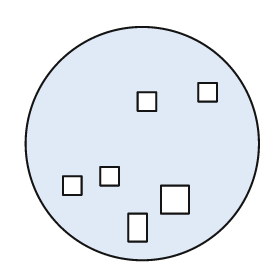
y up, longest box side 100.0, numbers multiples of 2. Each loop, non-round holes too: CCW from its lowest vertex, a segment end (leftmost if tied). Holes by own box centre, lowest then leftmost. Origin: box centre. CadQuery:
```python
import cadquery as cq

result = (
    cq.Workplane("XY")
    .moveTo(0.0, 0.0)
    .circle(50.0)
    .moveTo(-6.0, -42.0)
    .lineTo(2.0, -42.0)
    .lineTo(2.0, -30.0)
    .lineTo(-6.0, -30.0)
    .close()
    .moveTo(8.0, -30.0)
    .lineTo(20.0, -30.0)
    .lineTo(20.0, -18.0)
    .lineTo(8.0, -18.0)
    .close()
    .moveTo(-34.0, -22.0)
    .lineTo(-26.0, -22.0)
    .lineTo(-26.0, -14.0)
    .lineTo(-34.0, -14.0)
    .close()
    .moveTo(-18.0, -18.0)
    .lineTo(-10.0, -18.0)
    .lineTo(-10.0, -10.0)
    .lineTo(-18.0, -10.0)
    .close()
    .moveTo(-2.0, 14.0)
    .lineTo(6.0, 14.0)
    .lineTo(6.0, 22.0)
    .lineTo(-2.0, 22.0)
    .close()
    .moveTo(24.0, 18.0)
    .lineTo(32.0, 18.0)
    .lineTo(32.0, 26.0)
    .lineTo(24.0, 26.0)
    .close()
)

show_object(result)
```